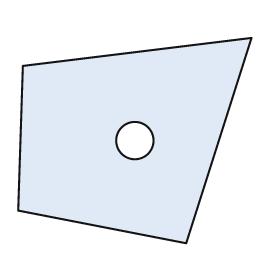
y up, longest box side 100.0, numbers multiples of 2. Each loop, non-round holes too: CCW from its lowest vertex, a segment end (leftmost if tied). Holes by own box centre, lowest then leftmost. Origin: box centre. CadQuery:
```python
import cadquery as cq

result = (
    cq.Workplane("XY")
    .moveTo(22.0, -44.0)
    .lineTo(50.0, 44.0)
    .lineTo(-48.0, 32.0)
    .lineTo(-50.0, -30.0)
    .close()
    .moveTo(0.0, 0.0)
    .circle(8.0)
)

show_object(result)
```